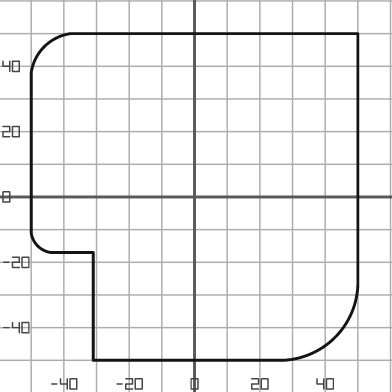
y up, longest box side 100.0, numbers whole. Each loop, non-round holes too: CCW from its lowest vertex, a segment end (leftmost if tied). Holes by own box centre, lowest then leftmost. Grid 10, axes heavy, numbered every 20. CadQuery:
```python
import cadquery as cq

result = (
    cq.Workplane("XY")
    .moveTo(-31.0, -50.0)
    .lineTo(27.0, -50.0)
    .threePointArc((43.0, -43.0), (50.0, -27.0))
    .lineTo(50.0, 50.0)
    .lineTo(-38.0, 50.0)
    .threePointArc((-46.0, 46.0), (-50.0, 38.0))
    .lineTo(-50.0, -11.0)
    .threePointArc((-48.0, -15.0), (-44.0, -17.0))
    .lineTo(-31.0, -17.0)
    .close()
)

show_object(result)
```